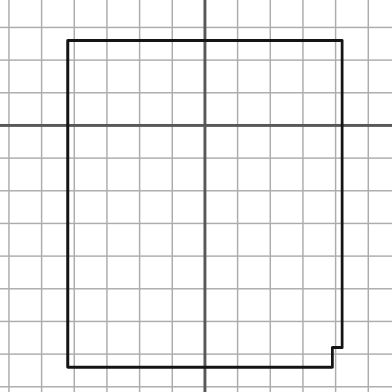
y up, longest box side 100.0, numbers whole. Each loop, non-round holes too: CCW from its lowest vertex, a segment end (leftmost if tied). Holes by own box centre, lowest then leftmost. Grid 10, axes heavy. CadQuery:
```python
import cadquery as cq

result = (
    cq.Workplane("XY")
    .moveTo(-42.0, -74.0)
    .lineTo(39.0, -74.0)
    .lineTo(39.0, -68.0)
    .lineTo(42.0, -68.0)
    .lineTo(42.0, 26.0)
    .lineTo(-42.0, 26.0)
    .close()
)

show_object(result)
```